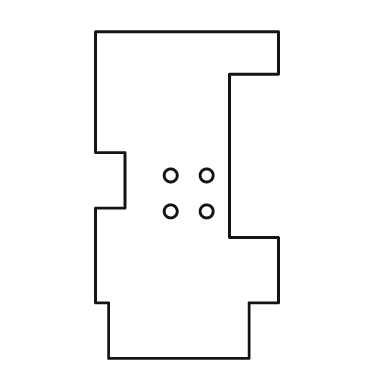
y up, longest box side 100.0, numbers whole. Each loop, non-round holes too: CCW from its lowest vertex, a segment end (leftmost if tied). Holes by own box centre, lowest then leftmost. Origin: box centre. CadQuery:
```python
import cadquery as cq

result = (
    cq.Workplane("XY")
    .moveTo(-24.0, -50.0)
    .lineTo(19.0, -50.0)
    .lineTo(19.0, -33.0)
    .lineTo(28.0, -33.0)
    .lineTo(28.0, -13.0)
    .lineTo(13.0, -13.0)
    .lineTo(13.0, 37.0)
    .lineTo(28.0, 37.0)
    .lineTo(28.0, 50.0)
    .lineTo(-28.0, 50.0)
    .lineTo(-28.0, 13.0)
    .lineTo(-19.0, 13.0)
    .lineTo(-19.0, -4.0)
    .lineTo(-28.0, -4.0)
    .lineTo(-28.0, -33.0)
    .lineTo(-24.0, -33.0)
    .close()
    .moveTo(-5.0, -5.0)
    .circle(2.0)
    .moveTo(6.0, -5.0)
    .circle(2.0)
    .moveTo(-5.0, 6.0)
    .circle(2.0)
    .moveTo(6.0, 6.0)
    .circle(2.0)
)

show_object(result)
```